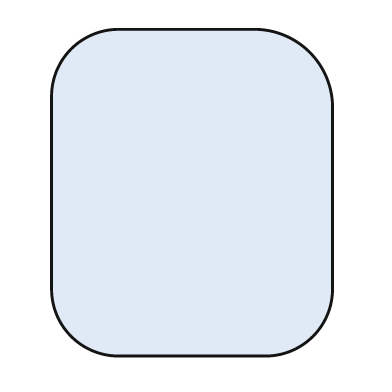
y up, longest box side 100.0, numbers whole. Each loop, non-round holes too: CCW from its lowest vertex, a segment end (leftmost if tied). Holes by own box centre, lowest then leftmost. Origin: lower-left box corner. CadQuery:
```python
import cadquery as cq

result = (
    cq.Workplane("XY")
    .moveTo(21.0, 0.0)
    .lineTo(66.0, 0.0)
    .threePointArc((80.0, 6.0), (86.0, 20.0))
    .lineTo(86.0, 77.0)
    .threePointArc((79.0, 93.0), (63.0, 100.0))
    .lineTo(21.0, 100.0)
    .threePointArc((6.0, 94.0), (0.0, 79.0))
    .lineTo(0.0, 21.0)
    .threePointArc((6.0, 6.0), (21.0, 0.0))
    .close()
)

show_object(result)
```